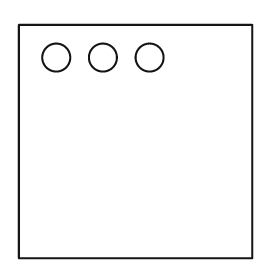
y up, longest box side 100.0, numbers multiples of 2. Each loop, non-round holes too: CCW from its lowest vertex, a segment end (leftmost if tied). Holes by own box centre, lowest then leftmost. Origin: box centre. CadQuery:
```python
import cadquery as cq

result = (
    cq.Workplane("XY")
    .moveTo(-50.0, -50.0)
    .lineTo(50.0, -50.0)
    .lineTo(50.0, 50.0)
    .lineTo(-50.0, 50.0)
    .close()
    .moveTo(-34.0, 36.0)
    .circle(6.0)
    .moveTo(-14.0, 36.0)
    .circle(6.0)
    .moveTo(6.0, 36.0)
    .circle(6.0)
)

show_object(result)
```